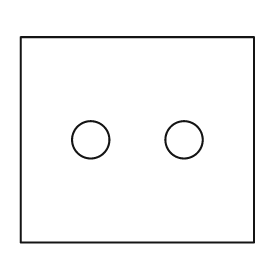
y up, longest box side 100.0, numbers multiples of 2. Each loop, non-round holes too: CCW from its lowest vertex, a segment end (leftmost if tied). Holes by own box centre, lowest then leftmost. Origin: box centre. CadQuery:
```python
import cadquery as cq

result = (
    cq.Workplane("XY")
    .moveTo(-50.0, -44.0)
    .lineTo(50.0, -44.0)
    .lineTo(50.0, 44.0)
    .lineTo(-50.0, 44.0)
    .close()
    .moveTo(-20.0, 0.0)
    .circle(8.0)
    .moveTo(20.0, 0.0)
    .circle(8.0)
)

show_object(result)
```